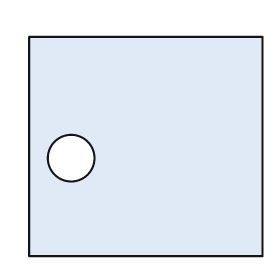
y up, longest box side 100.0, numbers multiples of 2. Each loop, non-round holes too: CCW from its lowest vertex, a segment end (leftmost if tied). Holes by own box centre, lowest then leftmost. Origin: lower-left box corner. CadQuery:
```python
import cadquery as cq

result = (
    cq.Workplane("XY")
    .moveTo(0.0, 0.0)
    .lineTo(100.0, 0.0)
    .lineTo(100.0, 94.0)
    .lineTo(0.0, 94.0)
    .close()
    .moveTo(18.0, 42.0)
    .circle(10.0)
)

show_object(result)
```